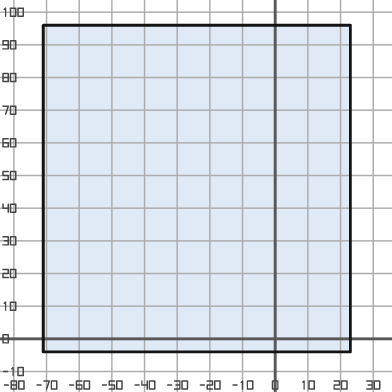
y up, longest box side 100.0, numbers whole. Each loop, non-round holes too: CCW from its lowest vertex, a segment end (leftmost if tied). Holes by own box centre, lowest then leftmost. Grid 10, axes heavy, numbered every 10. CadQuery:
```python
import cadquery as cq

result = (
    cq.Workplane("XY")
    .moveTo(-71.0, -4.0)
    .lineTo(23.0, -4.0)
    .lineTo(23.0, 96.0)
    .lineTo(-71.0, 96.0)
    .close()
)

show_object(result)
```